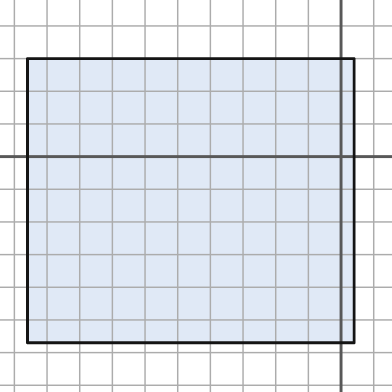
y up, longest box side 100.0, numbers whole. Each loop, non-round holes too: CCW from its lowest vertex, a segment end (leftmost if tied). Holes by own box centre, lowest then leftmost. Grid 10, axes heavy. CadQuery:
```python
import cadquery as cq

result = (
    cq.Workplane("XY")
    .moveTo(-96.0, -57.0)
    .lineTo(4.0, -57.0)
    .lineTo(4.0, 30.0)
    .lineTo(-96.0, 30.0)
    .close()
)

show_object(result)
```